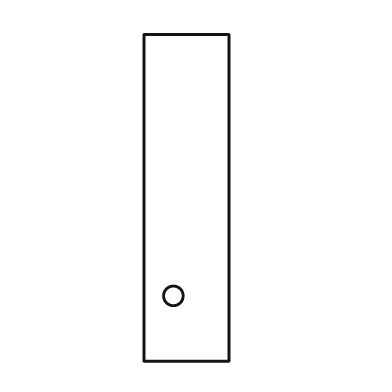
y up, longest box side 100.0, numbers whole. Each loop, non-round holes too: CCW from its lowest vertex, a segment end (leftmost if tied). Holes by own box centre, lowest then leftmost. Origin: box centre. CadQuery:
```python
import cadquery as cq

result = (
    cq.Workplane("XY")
    .moveTo(-13.0, -50.0)
    .lineTo(13.0, -50.0)
    .lineTo(13.0, 50.0)
    .lineTo(-13.0, 50.0)
    .close()
    .moveTo(-4.0, -30.0)
    .circle(3.0)
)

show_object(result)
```